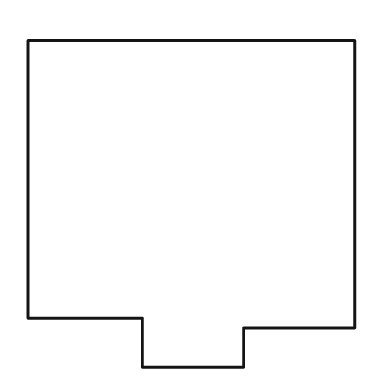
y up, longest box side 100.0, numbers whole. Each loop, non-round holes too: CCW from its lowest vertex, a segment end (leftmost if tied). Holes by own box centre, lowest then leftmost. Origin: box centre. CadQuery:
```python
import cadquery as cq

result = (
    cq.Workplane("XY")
    .moveTo(-15.0, -50.0)
    .lineTo(16.0, -50.0)
    .lineTo(16.0, -38.0)
    .lineTo(50.0, -38.0)
    .lineTo(50.0, 50.0)
    .lineTo(-50.0, 50.0)
    .lineTo(-50.0, -35.0)
    .lineTo(-15.0, -35.0)
    .close()
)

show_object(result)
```